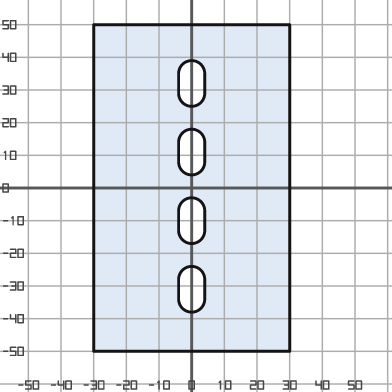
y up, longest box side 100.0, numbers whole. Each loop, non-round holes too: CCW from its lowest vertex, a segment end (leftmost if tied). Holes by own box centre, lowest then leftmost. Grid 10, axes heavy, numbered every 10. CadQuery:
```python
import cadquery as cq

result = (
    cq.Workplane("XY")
    .moveTo(-30.0, -50.0)
    .lineTo(30.0, -50.0)
    .lineTo(30.0, 50.0)
    .lineTo(-30.0, 50.0)
    .close()
    .moveTo(-4.0, -34.0)
    .threePointArc((0.0, -38.0), (4.0, -34.0))
    .lineTo(4.0, -28.0)
    .threePointArc((0.0, -24.0), (-4.0, -28.0))
    .close()
    .moveTo(-4.0, -13.0)
    .threePointArc((0.0, -17.0), (4.0, -13.0))
    .lineTo(4.0, -7.0)
    .threePointArc((0.0, -3.0), (-4.0, -7.0))
    .close()
    .moveTo(-4.0, 8.0)
    .threePointArc((0.0, 4.0), (4.0, 8.0))
    .lineTo(4.0, 14.0)
    .threePointArc((0.0, 18.0), (-4.0, 14.0))
    .close()
    .moveTo(-4.0, 29.0)
    .threePointArc((0.0, 25.0), (4.0, 29.0))
    .lineTo(4.0, 35.0)
    .threePointArc((0.0, 39.0), (-4.0, 35.0))
    .close()
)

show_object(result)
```